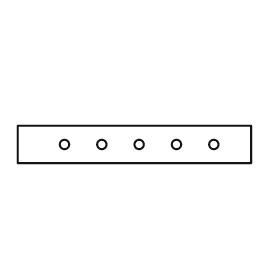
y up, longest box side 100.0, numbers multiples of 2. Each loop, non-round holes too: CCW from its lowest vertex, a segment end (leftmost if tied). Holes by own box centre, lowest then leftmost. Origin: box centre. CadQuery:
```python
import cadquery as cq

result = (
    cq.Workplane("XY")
    .moveTo(-50.0, -8.0)
    .lineTo(50.0, -8.0)
    .lineTo(50.0, 8.0)
    .lineTo(-50.0, 8.0)
    .close()
    .moveTo(-30.0, 0.0)
    .circle(2.0)
    .moveTo(-14.0, 0.0)
    .circle(2.0)
    .moveTo(2.0, 0.0)
    .circle(2.0)
    .moveTo(18.0, 0.0)
    .circle(2.0)
    .moveTo(34.0, 0.0)
    .circle(2.0)
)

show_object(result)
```